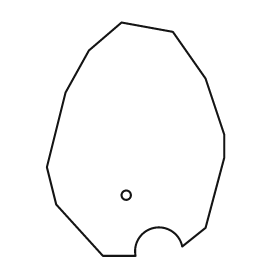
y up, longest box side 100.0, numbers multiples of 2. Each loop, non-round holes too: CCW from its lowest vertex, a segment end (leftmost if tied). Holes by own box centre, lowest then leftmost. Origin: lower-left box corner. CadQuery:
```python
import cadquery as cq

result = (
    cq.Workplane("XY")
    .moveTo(24.0, 0.0)
    .lineTo(38.0, 0.0)
    .threePointArc((46.0, 12.0), (58.0, 4.0))
    .lineTo(68.0, 12.0)
    .lineTo(76.0, 42.0)
    .lineTo(76.0, 52.0)
    .lineTo(68.0, 76.0)
    .lineTo(54.0, 96.0)
    .lineTo(32.0, 100.0)
    .lineTo(18.0, 88.0)
    .lineTo(8.0, 70.0)
    .lineTo(0.0, 38.0)
    .lineTo(4.0, 22.0)
    .close()
    .moveTo(34.0, 26.0)
    .circle(2.0)
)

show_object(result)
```